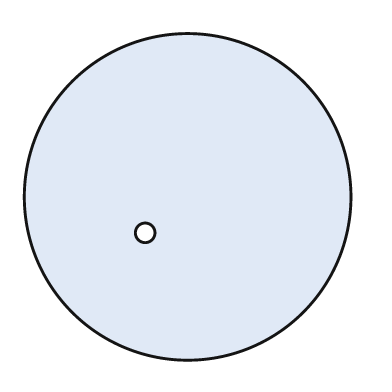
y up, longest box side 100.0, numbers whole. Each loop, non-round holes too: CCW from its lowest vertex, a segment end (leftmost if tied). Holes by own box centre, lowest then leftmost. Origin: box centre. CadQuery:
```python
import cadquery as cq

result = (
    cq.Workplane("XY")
    .moveTo(0.0, 0.0)
    .circle(50.0)
    .moveTo(-13.0, -11.0)
    .circle(3.0)
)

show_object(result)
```